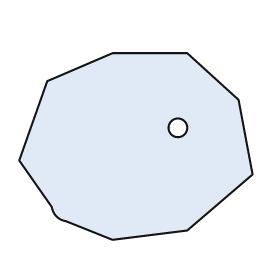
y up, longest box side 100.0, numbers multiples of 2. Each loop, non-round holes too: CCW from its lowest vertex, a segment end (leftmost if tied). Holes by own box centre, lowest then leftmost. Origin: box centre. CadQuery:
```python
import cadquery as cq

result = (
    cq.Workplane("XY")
    .moveTo(-10.0, -40.0)
    .lineTo(22.0, -36.0)
    .lineTo(50.0, -12.0)
    .lineTo(44.0, 20.0)
    .lineTo(22.0, 40.0)
    .lineTo(-10.0, 40.0)
    .lineTo(-38.0, 28.0)
    .lineTo(-50.0, -6.0)
    .lineTo(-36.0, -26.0)
    .threePointArc((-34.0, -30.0), (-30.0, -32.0))
    .close()
    .moveTo(18.0, 8.0)
    .circle(4.0)
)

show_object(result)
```